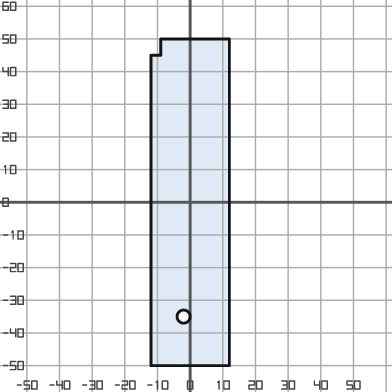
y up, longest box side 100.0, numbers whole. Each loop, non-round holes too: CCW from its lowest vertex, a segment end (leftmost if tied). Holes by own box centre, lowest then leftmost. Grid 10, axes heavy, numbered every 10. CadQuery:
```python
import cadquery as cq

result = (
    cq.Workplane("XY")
    .moveTo(-12.0, -50.0)
    .lineTo(12.0, -50.0)
    .lineTo(12.0, 50.0)
    .lineTo(-9.0, 50.0)
    .lineTo(-9.0, 45.0)
    .lineTo(-12.0, 45.0)
    .close()
    .moveTo(-2.0, -35.0)
    .circle(2.0)
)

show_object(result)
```